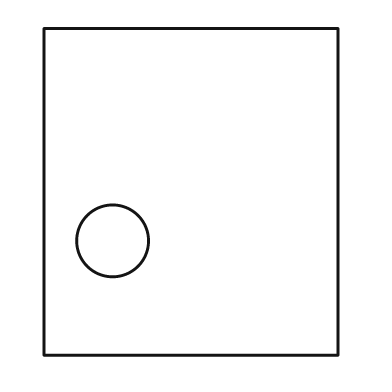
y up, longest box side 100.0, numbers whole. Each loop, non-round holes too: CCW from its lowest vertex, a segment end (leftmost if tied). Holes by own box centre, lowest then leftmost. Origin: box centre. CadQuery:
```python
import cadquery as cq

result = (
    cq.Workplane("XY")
    .moveTo(-45.0, -50.0)
    .lineTo(45.0, -50.0)
    .lineTo(45.0, 50.0)
    .lineTo(-45.0, 50.0)
    .close()
    .moveTo(-24.0, -15.0)
    .circle(11.0)
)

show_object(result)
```